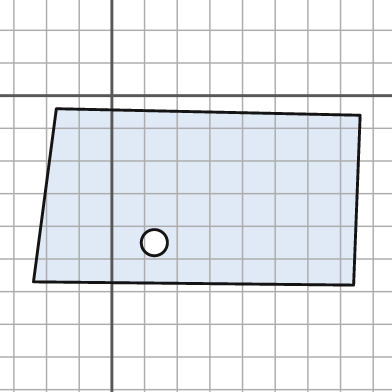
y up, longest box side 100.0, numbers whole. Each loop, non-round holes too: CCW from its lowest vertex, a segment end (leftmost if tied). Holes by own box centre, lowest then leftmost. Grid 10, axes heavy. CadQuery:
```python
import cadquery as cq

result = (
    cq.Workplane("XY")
    .moveTo(74.0, -58.0)
    .lineTo(76.0, -6.0)
    .lineTo(-17.0, -4.0)
    .lineTo(-24.0, -57.0)
    .close()
    .moveTo(13.0, -45.0)
    .circle(4.0)
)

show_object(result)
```